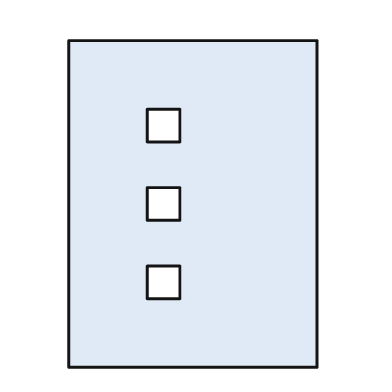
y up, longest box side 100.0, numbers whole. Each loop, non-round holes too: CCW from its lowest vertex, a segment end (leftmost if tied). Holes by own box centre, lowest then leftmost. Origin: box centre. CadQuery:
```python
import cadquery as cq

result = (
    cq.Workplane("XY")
    .moveTo(-38.0, -50.0)
    .lineTo(38.0, -50.0)
    .lineTo(38.0, 50.0)
    .lineTo(-38.0, 50.0)
    .close()
    .moveTo(-14.0, -29.0)
    .lineTo(-4.0, -29.0)
    .lineTo(-4.0, -19.0)
    .lineTo(-14.0, -19.0)
    .close()
    .moveTo(-14.0, -5.0)
    .lineTo(-4.0, -5.0)
    .lineTo(-4.0, 5.0)
    .lineTo(-14.0, 5.0)
    .close()
    .moveTo(-14.0, 19.0)
    .lineTo(-4.0, 19.0)
    .lineTo(-4.0, 29.0)
    .lineTo(-14.0, 29.0)
    .close()
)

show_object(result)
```